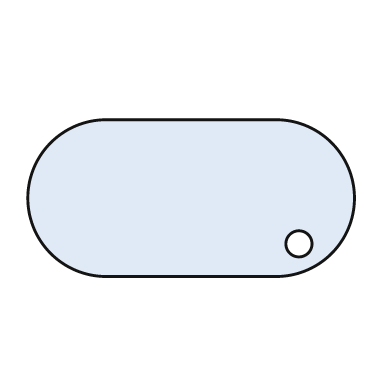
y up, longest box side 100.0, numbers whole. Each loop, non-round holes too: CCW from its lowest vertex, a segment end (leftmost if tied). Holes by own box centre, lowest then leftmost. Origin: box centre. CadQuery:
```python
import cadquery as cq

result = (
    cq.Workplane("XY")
    .moveTo(-26.0, -24.0)
    .lineTo(26.0, -24.0)
    .threePointArc((50.0, 0.0), (26.0, 24.0))
    .lineTo(-26.0, 24.0)
    .threePointArc((-50.0, 0.0), (-26.0, -24.0))
    .close()
    .moveTo(33.0, -14.0)
    .circle(4.0)
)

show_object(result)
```